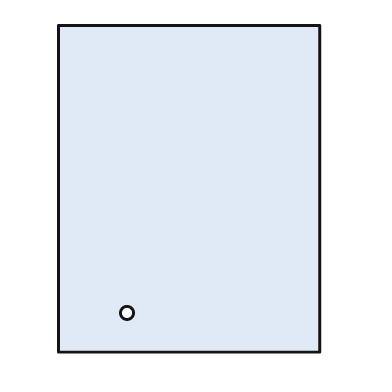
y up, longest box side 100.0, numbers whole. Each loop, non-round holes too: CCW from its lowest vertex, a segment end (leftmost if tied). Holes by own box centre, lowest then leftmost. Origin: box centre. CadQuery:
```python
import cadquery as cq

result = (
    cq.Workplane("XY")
    .moveTo(-40.0, -50.0)
    .lineTo(40.0, -50.0)
    .lineTo(40.0, 50.0)
    .lineTo(-40.0, 50.0)
    .close()
    .moveTo(-19.0, -38.0)
    .circle(2.0)
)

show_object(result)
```